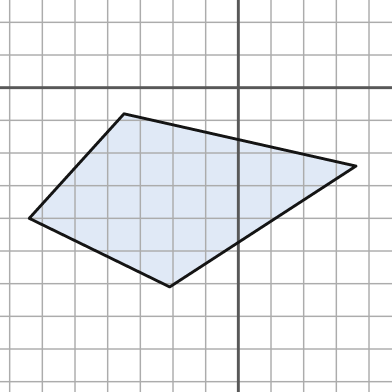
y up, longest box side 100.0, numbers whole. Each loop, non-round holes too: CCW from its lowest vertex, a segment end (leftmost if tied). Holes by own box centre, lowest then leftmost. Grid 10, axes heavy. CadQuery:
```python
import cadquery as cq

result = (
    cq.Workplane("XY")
    .moveTo(-21.0, -61.0)
    .lineTo(36.0, -24.0)
    .lineTo(-35.0, -8.0)
    .lineTo(-64.0, -40.0)
    .close()
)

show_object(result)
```